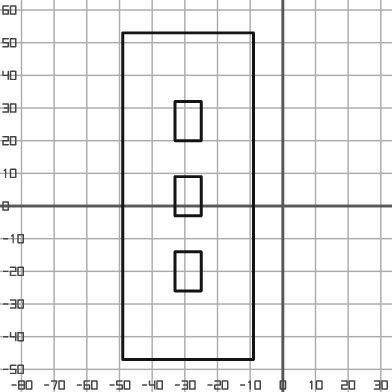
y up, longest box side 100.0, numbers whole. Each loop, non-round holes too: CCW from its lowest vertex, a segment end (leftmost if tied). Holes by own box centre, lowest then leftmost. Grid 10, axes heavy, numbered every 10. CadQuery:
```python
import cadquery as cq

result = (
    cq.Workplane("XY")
    .moveTo(-49.0, -47.0)
    .lineTo(-9.0, -47.0)
    .lineTo(-9.0, 53.0)
    .lineTo(-49.0, 53.0)
    .close()
    .moveTo(-33.0, -26.0)
    .lineTo(-25.0, -26.0)
    .lineTo(-25.0, -14.0)
    .lineTo(-33.0, -14.0)
    .close()
    .moveTo(-33.0, -3.0)
    .lineTo(-25.0, -3.0)
    .lineTo(-25.0, 9.0)
    .lineTo(-33.0, 9.0)
    .close()
    .moveTo(-33.0, 20.0)
    .lineTo(-25.0, 20.0)
    .lineTo(-25.0, 32.0)
    .lineTo(-33.0, 32.0)
    .close()
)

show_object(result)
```